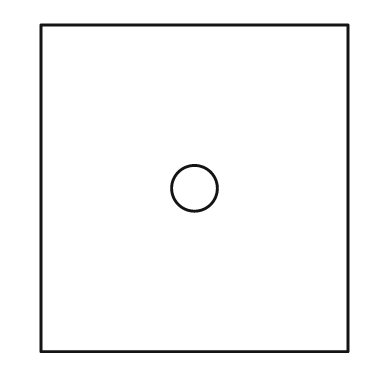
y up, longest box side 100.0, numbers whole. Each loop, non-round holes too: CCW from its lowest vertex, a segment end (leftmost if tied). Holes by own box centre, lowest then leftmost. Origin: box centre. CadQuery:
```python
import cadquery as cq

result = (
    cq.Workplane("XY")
    .moveTo(-47.0, -50.0)
    .lineTo(47.0, -50.0)
    .lineTo(47.0, 50.0)
    .lineTo(-47.0, 50.0)
    .close()
    .moveTo(0.0, 0.0)
    .circle(7.0)
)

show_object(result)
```